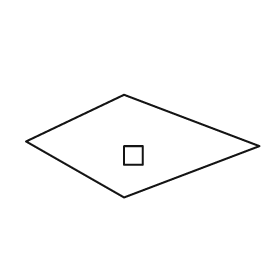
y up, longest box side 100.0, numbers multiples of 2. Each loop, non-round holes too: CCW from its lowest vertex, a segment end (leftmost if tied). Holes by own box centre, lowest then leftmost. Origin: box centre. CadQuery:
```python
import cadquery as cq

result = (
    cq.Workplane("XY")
    .moveTo(-8.0, -22.0)
    .lineTo(50.0, 0.0)
    .lineTo(-8.0, 22.0)
    .lineTo(-50.0, 2.0)
    .close()
    .moveTo(-8.0, -8.0)
    .lineTo(0.0, -8.0)
    .lineTo(0.0, 0.0)
    .lineTo(-8.0, 0.0)
    .close()
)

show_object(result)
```